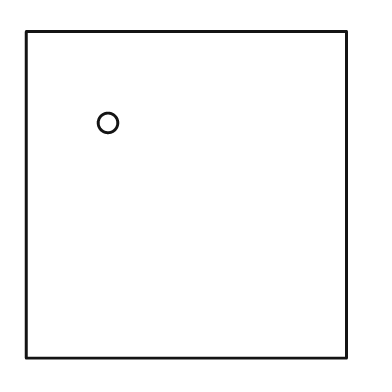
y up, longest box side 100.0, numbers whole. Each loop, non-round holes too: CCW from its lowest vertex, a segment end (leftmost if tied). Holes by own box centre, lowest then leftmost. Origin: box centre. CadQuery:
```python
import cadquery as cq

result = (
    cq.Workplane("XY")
    .moveTo(-49.0, -50.0)
    .lineTo(49.0, -50.0)
    .lineTo(49.0, 50.0)
    .lineTo(-49.0, 50.0)
    .close()
    .moveTo(-24.0, 22.0)
    .circle(3.0)
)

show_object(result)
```